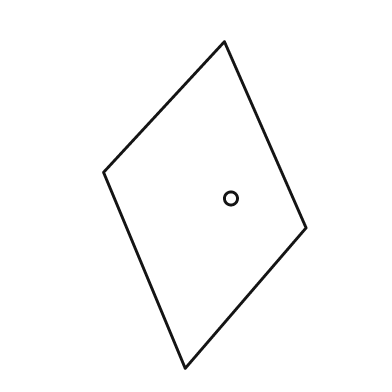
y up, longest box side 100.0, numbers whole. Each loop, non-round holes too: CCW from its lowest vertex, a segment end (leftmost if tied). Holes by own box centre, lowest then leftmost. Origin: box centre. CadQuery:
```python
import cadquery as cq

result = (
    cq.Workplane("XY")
    .moveTo(-6.0, -50.0)
    .lineTo(31.0, -7.0)
    .lineTo(6.0, 50.0)
    .lineTo(-31.0, 10.0)
    .close()
    .moveTo(8.0, 2.0)
    .circle(2.0)
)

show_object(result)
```